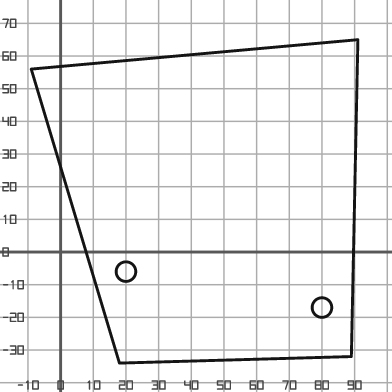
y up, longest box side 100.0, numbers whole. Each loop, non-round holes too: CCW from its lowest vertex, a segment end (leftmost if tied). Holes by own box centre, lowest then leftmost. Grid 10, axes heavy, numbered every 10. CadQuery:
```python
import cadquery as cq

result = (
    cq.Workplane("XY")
    .moveTo(18.0, -34.0)
    .lineTo(89.0, -32.0)
    .lineTo(91.0, 65.0)
    .lineTo(-9.0, 56.0)
    .close()
    .moveTo(80.0, -17.0)
    .circle(3.0)
    .moveTo(20.0, -6.0)
    .circle(3.0)
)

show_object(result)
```